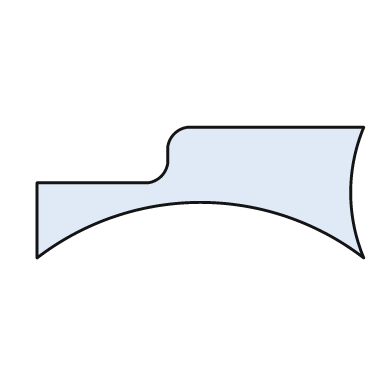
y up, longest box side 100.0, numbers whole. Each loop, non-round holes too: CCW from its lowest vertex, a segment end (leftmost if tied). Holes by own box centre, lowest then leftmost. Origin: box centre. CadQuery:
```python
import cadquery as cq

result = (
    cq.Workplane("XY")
    .moveTo(-50.0, -20.0)
    .threePointArc((0.0, -3.0), (50.0, -20.0))
    .threePointArc((46.0, 0.0), (50.0, 20.0))
    .lineTo(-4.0, 20.0)
    .threePointArc((-8.0, 18.0), (-10.0, 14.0))
    .lineTo(-10.0, 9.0)
    .threePointArc((-12.0, 5.0), (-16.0, 3.0))
    .lineTo(-50.0, 3.0)
    .close()
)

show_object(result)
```